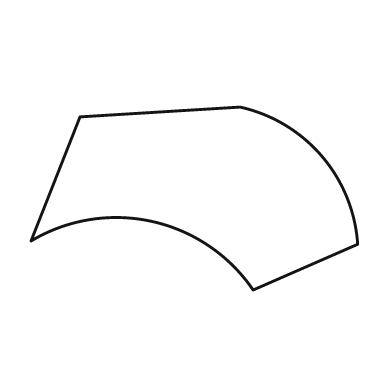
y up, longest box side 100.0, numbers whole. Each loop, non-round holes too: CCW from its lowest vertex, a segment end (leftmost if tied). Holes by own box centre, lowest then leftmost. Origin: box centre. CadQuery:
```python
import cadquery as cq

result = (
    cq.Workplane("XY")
    .moveTo(18.0, -28.0)
    .lineTo(50.0, -14.0)
    .threePointArc((39.0, 13.0), (14.0, 28.0))
    .lineTo(-35.0, 25.0)
    .lineTo(-50.0, -13.0)
    .threePointArc((-13.0, -7.0), (18.0, -28.0))
    .close()
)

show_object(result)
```